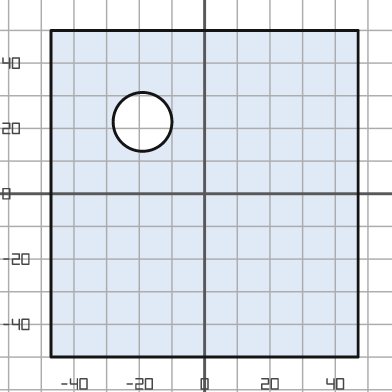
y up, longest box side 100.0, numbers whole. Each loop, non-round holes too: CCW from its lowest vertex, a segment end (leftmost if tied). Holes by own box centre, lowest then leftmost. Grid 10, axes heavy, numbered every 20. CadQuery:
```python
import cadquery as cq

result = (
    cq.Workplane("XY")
    .moveTo(-47.0, -50.0)
    .lineTo(47.0, -50.0)
    .lineTo(47.0, 50.0)
    .lineTo(-47.0, 50.0)
    .close()
    .moveTo(-19.0, 22.0)
    .circle(9.0)
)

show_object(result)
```